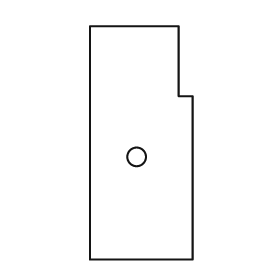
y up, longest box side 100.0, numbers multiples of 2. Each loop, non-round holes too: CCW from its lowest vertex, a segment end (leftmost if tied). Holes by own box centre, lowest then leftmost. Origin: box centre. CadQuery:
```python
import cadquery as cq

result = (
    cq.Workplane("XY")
    .moveTo(-22.0, -50.0)
    .lineTo(22.0, -50.0)
    .lineTo(22.0, 20.0)
    .lineTo(16.0, 20.0)
    .lineTo(16.0, 50.0)
    .lineTo(-22.0, 50.0)
    .close()
    .moveTo(-2.0, -6.0)
    .circle(4.0)
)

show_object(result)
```